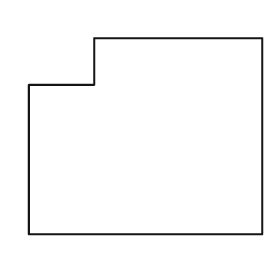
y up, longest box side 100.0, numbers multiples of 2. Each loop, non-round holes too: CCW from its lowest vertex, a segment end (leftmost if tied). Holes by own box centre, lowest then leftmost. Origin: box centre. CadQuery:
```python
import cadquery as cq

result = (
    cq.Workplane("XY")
    .moveTo(-50.0, -42.0)
    .lineTo(50.0, -42.0)
    .lineTo(50.0, 42.0)
    .lineTo(-22.0, 42.0)
    .lineTo(-22.0, 22.0)
    .lineTo(-50.0, 22.0)
    .close()
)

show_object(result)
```